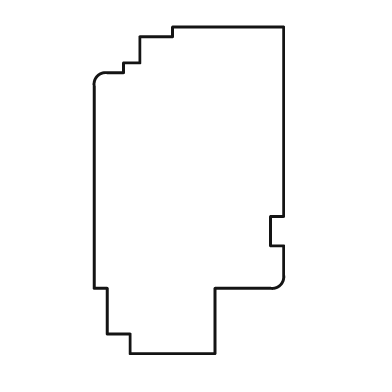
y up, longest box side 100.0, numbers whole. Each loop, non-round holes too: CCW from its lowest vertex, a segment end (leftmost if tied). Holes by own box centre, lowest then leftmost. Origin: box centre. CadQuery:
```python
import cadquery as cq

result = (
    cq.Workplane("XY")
    .moveTo(-18.0, -50.0)
    .lineTo(8.0, -50.0)
    .lineTo(8.0, -30.0)
    .lineTo(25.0, -30.0)
    .threePointArc((28.0, -29.0), (29.0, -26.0))
    .lineTo(29.0, -17.0)
    .lineTo(25.0, -17.0)
    .lineTo(25.0, -8.0)
    .lineTo(29.0, -8.0)
    .lineTo(29.0, 50.0)
    .lineTo(-5.0, 50.0)
    .lineTo(-5.0, 47.0)
    .lineTo(-15.0, 47.0)
    .lineTo(-15.0, 39.0)
    .lineTo(-20.0, 39.0)
    .lineTo(-20.0, 36.0)
    .lineTo(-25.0, 36.0)
    .threePointArc((-28.0, 35.0), (-29.0, 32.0))
    .lineTo(-29.0, -30.0)
    .lineTo(-25.0, -30.0)
    .lineTo(-25.0, -44.0)
    .lineTo(-18.0, -44.0)
    .close()
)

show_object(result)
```